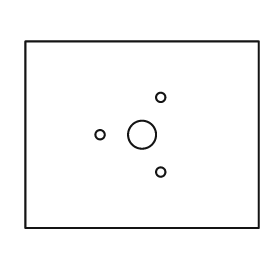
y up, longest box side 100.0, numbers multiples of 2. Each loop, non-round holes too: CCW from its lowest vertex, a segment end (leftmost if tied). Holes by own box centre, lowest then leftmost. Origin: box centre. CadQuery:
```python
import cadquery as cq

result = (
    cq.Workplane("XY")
    .moveTo(-50.0, -40.0)
    .lineTo(50.0, -40.0)
    .lineTo(50.0, 40.0)
    .lineTo(-50.0, 40.0)
    .close()
    .moveTo(8.0, -16.0)
    .circle(2.0)
    .moveTo(-18.0, 0.0)
    .circle(2.0)
    .moveTo(0.0, 0.0)
    .circle(6.0)
    .moveTo(8.0, 16.0)
    .circle(2.0)
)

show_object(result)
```